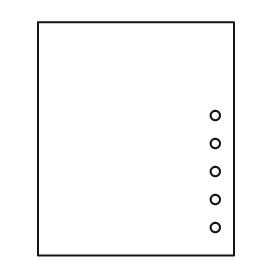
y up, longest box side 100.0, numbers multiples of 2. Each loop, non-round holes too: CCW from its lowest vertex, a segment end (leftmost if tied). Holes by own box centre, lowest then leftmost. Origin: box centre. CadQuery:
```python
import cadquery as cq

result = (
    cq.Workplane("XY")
    .moveTo(-42.0, -50.0)
    .lineTo(42.0, -50.0)
    .lineTo(42.0, 50.0)
    .lineTo(-42.0, 50.0)
    .close()
    .moveTo(34.0, -38.0)
    .circle(2.0)
    .moveTo(34.0, -26.0)
    .circle(2.0)
    .moveTo(34.0, -14.0)
    .circle(2.0)
    .moveTo(34.0, -2.0)
    .circle(2.0)
    .moveTo(34.0, 10.0)
    .circle(2.0)
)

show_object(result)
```